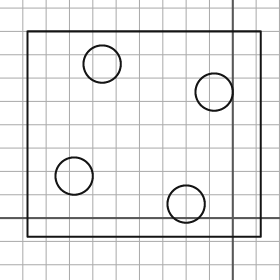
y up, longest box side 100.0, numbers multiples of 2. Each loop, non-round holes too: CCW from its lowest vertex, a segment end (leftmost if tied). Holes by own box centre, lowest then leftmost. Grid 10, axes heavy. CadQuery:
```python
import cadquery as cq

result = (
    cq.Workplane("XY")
    .moveTo(-88.0, -8.0)
    .lineTo(12.0, -8.0)
    .lineTo(12.0, 80.0)
    .lineTo(-88.0, 80.0)
    .close()
    .moveTo(-20.0, 6.0)
    .circle(8.0)
    .moveTo(-68.0, 18.0)
    .circle(8.0)
    .moveTo(-8.0, 54.0)
    .circle(8.0)
    .moveTo(-56.0, 66.0)
    .circle(8.0)
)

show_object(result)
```